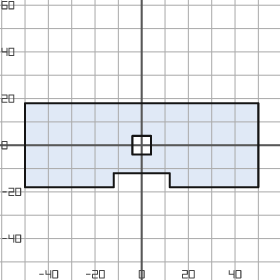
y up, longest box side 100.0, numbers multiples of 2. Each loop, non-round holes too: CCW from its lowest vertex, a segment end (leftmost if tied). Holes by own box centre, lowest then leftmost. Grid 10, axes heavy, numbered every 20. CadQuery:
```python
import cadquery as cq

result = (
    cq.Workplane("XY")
    .moveTo(-50.0, -18.0)
    .lineTo(-12.0, -18.0)
    .lineTo(-12.0, -12.0)
    .lineTo(12.0, -12.0)
    .lineTo(12.0, -18.0)
    .lineTo(50.0, -18.0)
    .lineTo(50.0, 18.0)
    .lineTo(-50.0, 18.0)
    .close()
    .moveTo(-4.0, -4.0)
    .lineTo(4.0, -4.0)
    .lineTo(4.0, 4.0)
    .lineTo(-4.0, 4.0)
    .close()
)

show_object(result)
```